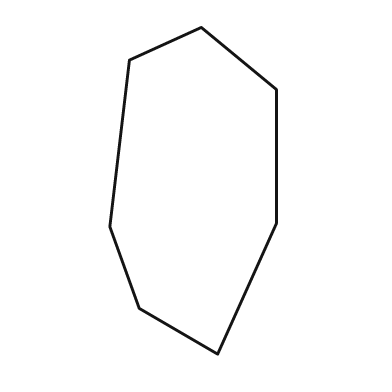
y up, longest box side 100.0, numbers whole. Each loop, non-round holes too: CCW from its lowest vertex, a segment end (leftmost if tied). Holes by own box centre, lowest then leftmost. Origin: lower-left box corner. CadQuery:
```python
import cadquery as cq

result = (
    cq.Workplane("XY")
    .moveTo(33.0, 0.0)
    .lineTo(51.0, 40.0)
    .lineTo(51.0, 81.0)
    .lineTo(28.0, 100.0)
    .lineTo(6.0, 90.0)
    .lineTo(0.0, 39.0)
    .lineTo(9.0, 14.0)
    .close()
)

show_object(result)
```